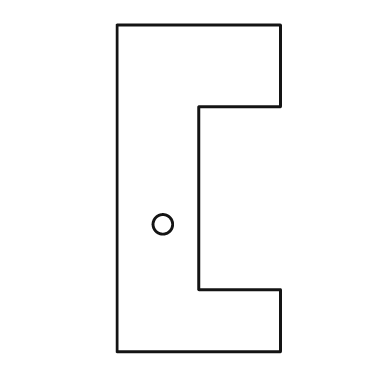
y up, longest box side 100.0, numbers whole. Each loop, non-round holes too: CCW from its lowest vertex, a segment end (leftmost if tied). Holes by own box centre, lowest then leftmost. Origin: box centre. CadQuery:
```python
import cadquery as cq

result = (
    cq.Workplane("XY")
    .moveTo(-25.0, -50.0)
    .lineTo(25.0, -50.0)
    .lineTo(25.0, -31.0)
    .lineTo(0.0, -31.0)
    .lineTo(0.0, 25.0)
    .lineTo(25.0, 25.0)
    .lineTo(25.0, 50.0)
    .lineTo(-25.0, 50.0)
    .close()
    .moveTo(-11.0, -11.0)
    .circle(3.0)
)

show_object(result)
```